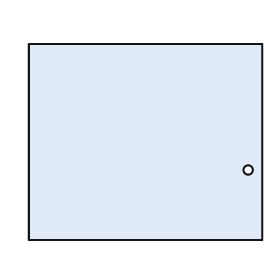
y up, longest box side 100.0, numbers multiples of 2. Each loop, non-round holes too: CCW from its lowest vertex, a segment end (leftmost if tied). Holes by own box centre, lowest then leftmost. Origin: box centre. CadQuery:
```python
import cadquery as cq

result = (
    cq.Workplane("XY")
    .moveTo(-50.0, -42.0)
    .lineTo(50.0, -42.0)
    .lineTo(50.0, 42.0)
    .lineTo(-50.0, 42.0)
    .close()
    .moveTo(44.0, -12.0)
    .circle(2.0)
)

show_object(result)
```